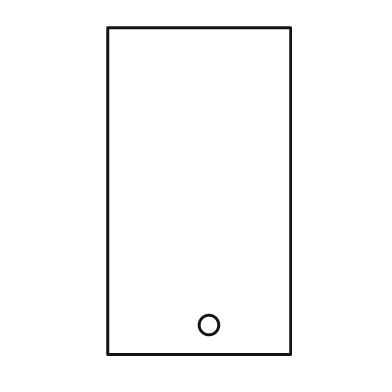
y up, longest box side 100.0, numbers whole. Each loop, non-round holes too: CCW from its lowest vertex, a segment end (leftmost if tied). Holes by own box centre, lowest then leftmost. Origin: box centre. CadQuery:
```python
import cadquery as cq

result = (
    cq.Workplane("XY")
    .moveTo(-28.0, -50.0)
    .lineTo(28.0, -50.0)
    .lineTo(28.0, 50.0)
    .lineTo(-28.0, 50.0)
    .close()
    .moveTo(3.0, -41.0)
    .circle(3.0)
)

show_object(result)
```